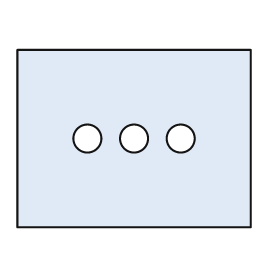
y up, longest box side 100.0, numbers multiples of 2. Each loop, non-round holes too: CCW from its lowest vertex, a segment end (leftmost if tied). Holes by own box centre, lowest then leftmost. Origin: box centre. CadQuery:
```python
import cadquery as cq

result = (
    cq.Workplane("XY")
    .moveTo(-50.0, -38.0)
    .lineTo(50.0, -38.0)
    .lineTo(50.0, 38.0)
    .lineTo(-50.0, 38.0)
    .close()
    .moveTo(-20.0, 0.0)
    .circle(6.0)
    .moveTo(0.0, 0.0)
    .circle(6.0)
    .moveTo(20.0, 0.0)
    .circle(6.0)
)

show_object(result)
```